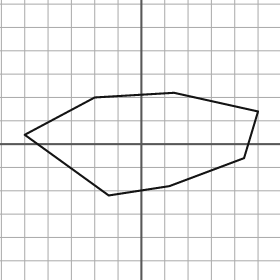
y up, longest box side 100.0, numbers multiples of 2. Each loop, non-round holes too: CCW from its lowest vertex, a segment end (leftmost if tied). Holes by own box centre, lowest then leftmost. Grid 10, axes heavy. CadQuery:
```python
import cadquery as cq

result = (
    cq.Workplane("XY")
    .moveTo(-14.0, -22.0)
    .lineTo(12.0, -18.0)
    .lineTo(44.0, -6.0)
    .lineTo(50.0, 14.0)
    .lineTo(14.0, 22.0)
    .lineTo(-20.0, 20.0)
    .lineTo(-50.0, 4.0)
    .close()
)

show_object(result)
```